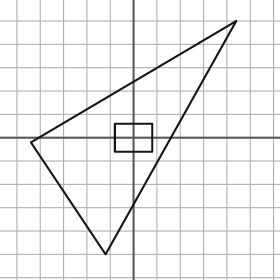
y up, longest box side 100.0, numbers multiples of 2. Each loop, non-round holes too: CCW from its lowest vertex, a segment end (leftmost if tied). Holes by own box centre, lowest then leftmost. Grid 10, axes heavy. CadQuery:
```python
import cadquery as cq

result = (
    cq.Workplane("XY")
    .moveTo(-12.0, -50.0)
    .lineTo(44.0, 50.0)
    .lineTo(-44.0, -2.0)
    .close()
    .moveTo(-8.0, -6.0)
    .lineTo(8.0, -6.0)
    .lineTo(8.0, 6.0)
    .lineTo(-8.0, 6.0)
    .close()
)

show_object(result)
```